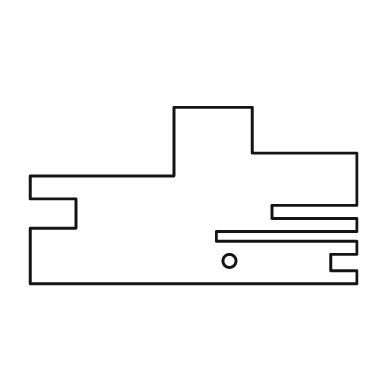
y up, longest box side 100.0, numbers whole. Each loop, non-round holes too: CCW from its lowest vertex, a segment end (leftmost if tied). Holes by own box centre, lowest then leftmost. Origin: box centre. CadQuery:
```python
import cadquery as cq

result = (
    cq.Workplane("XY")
    .moveTo(-50.0, -27.0)
    .lineTo(50.0, -27.0)
    .lineTo(50.0, -23.0)
    .lineTo(42.0, -23.0)
    .lineTo(42.0, -18.0)
    .lineTo(50.0, -18.0)
    .lineTo(50.0, -14.0)
    .lineTo(7.0, -14.0)
    .lineTo(7.0, -11.0)
    .lineTo(50.0, -11.0)
    .lineTo(50.0, -7.0)
    .lineTo(24.0, -7.0)
    .lineTo(24.0, -3.0)
    .lineTo(50.0, -3.0)
    .lineTo(50.0, 13.0)
    .lineTo(18.0, 13.0)
    .lineTo(18.0, 27.0)
    .lineTo(-6.0, 27.0)
    .lineTo(-6.0, 6.0)
    .lineTo(-50.0, 6.0)
    .lineTo(-50.0, -1.0)
    .lineTo(-36.0, -1.0)
    .lineTo(-36.0, -10.0)
    .lineTo(-50.0, -10.0)
    .close()
    .moveTo(11.0, -20.0)
    .circle(2.0)
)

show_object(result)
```